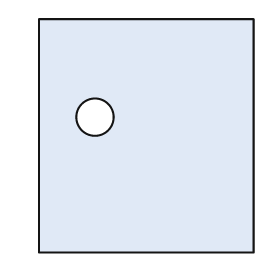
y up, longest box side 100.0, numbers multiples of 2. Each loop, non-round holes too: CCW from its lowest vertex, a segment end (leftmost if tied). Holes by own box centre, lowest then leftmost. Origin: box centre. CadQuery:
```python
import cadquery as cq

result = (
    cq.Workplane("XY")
    .moveTo(-46.0, -50.0)
    .lineTo(46.0, -50.0)
    .lineTo(46.0, 50.0)
    .lineTo(-46.0, 50.0)
    .close()
    .moveTo(-22.0, 8.0)
    .circle(8.0)
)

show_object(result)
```